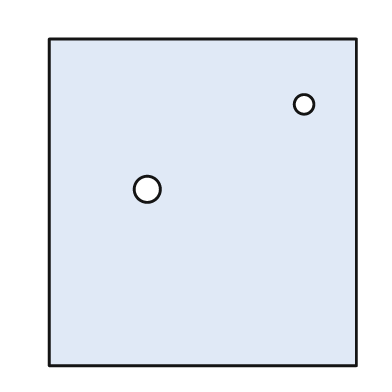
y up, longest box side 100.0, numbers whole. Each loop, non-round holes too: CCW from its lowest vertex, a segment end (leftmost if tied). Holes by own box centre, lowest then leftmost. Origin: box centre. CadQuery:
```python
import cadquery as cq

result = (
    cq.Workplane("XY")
    .moveTo(-47.0, -50.0)
    .lineTo(47.0, -50.0)
    .lineTo(47.0, 50.0)
    .lineTo(-47.0, 50.0)
    .close()
    .moveTo(-17.0, 4.0)
    .circle(4.0)
    .moveTo(31.0, 30.0)
    .circle(3.0)
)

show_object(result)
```